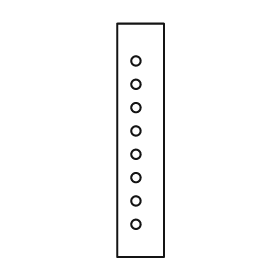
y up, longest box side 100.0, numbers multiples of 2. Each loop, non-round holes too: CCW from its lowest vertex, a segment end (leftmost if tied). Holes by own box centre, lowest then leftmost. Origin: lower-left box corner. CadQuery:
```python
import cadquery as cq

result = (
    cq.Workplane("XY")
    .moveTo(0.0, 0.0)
    .lineTo(20.0, 0.0)
    .lineTo(20.0, 100.0)
    .lineTo(0.0, 100.0)
    .close()
    .moveTo(8.0, 14.0)
    .circle(2.0)
    .moveTo(8.0, 24.0)
    .circle(2.0)
    .moveTo(8.0, 34.0)
    .circle(2.0)
    .moveTo(8.0, 44.0)
    .circle(2.0)
    .moveTo(8.0, 54.0)
    .circle(2.0)
    .moveTo(8.0, 64.0)
    .circle(2.0)
    .moveTo(8.0, 74.0)
    .circle(2.0)
    .moveTo(8.0, 84.0)
    .circle(2.0)
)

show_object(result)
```